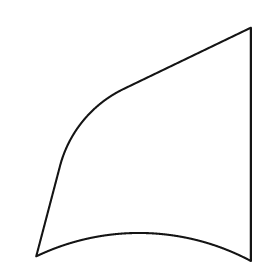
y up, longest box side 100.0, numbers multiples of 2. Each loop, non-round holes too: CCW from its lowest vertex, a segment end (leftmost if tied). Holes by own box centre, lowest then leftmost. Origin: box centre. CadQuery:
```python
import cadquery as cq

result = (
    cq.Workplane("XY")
    .moveTo(46.0, -50.0)
    .lineTo(46.0, 50.0)
    .lineTo(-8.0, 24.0)
    .threePointArc((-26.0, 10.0), (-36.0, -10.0))
    .lineTo(-46.0, -48.0)
    .threePointArc((0.0, -38.0), (46.0, -50.0))
    .close()
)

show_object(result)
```